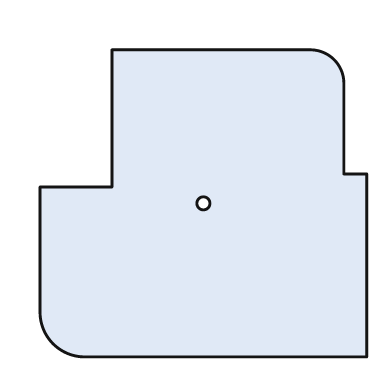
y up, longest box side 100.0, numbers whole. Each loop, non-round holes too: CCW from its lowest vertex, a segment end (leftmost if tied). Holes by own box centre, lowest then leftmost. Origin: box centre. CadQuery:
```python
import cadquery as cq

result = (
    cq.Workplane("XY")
    .moveTo(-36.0, -47.0)
    .lineTo(50.0, -47.0)
    .lineTo(50.0, 9.0)
    .lineTo(43.0, 9.0)
    .lineTo(43.0, 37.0)
    .threePointArc((40.0, 44.0), (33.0, 47.0))
    .lineTo(-28.0, 47.0)
    .lineTo(-28.0, 5.0)
    .lineTo(-50.0, 5.0)
    .lineTo(-50.0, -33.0)
    .threePointArc((-46.0, -43.0), (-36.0, -47.0))
    .close()
    .moveTo(0.0, 0.0)
    .circle(2.0)
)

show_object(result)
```